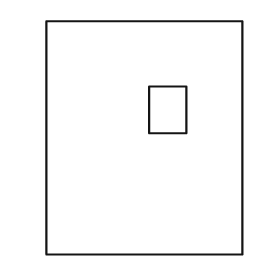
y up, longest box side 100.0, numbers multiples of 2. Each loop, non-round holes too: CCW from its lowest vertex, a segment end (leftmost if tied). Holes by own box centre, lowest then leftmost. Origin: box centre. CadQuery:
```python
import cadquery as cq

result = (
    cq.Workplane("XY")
    .moveTo(-42.0, -50.0)
    .lineTo(42.0, -50.0)
    .lineTo(42.0, 50.0)
    .lineTo(-42.0, 50.0)
    .close()
    .moveTo(2.0, 2.0)
    .lineTo(18.0, 2.0)
    .lineTo(18.0, 22.0)
    .lineTo(2.0, 22.0)
    .close()
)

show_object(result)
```